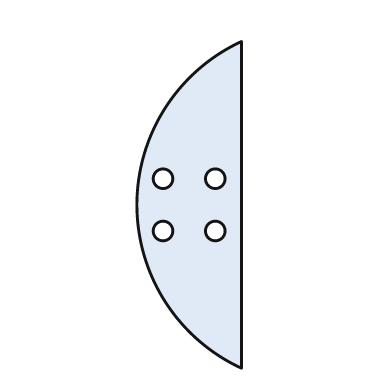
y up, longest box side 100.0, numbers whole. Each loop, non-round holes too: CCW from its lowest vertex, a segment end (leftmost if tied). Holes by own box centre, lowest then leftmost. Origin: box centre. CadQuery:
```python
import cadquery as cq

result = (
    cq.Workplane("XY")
    .moveTo(16.0, -50.0)
    .lineTo(16.0, 50.0)
    .threePointArc((-16.0, 0.0), (16.0, -50.0))
    .close()
    .moveTo(-8.0, -8.0)
    .circle(3.0)
    .moveTo(8.0, -8.0)
    .circle(3.0)
    .moveTo(-8.0, 8.0)
    .circle(3.0)
    .moveTo(8.0, 8.0)
    .circle(3.0)
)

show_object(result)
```